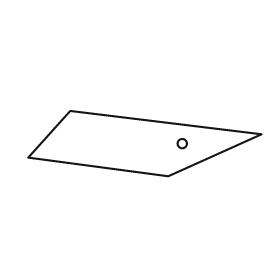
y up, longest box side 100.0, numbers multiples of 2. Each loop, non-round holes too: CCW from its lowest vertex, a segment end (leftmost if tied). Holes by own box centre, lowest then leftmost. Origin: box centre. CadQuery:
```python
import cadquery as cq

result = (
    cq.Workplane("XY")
    .moveTo(10.0, -14.0)
    .lineTo(50.0, 4.0)
    .lineTo(-32.0, 14.0)
    .lineTo(-50.0, -6.0)
    .close()
    .moveTo(16.0, 0.0)
    .circle(2.0)
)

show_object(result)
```